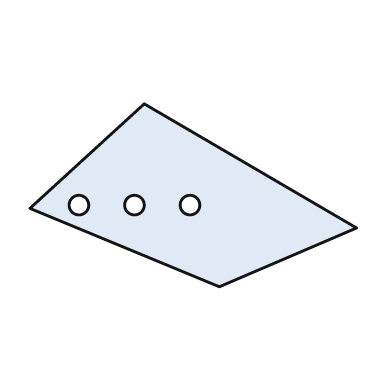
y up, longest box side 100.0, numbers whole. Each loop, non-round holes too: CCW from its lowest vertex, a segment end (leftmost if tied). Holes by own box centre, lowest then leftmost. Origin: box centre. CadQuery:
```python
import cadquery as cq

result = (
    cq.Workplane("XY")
    .moveTo(8.0, -28.0)
    .lineTo(50.0, -10.0)
    .lineTo(-15.0, 28.0)
    .lineTo(-50.0, -4.0)
    .close()
    .moveTo(-35.0, -3.0)
    .circle(3.0)
    .moveTo(-18.0, -3.0)
    .circle(3.0)
    .moveTo(-1.0, -3.0)
    .circle(3.0)
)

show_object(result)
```